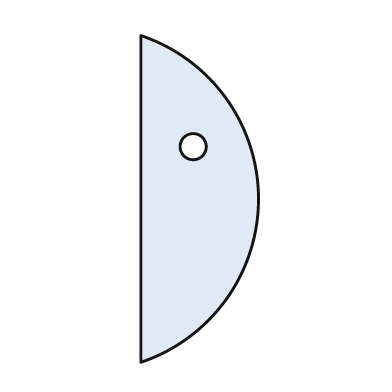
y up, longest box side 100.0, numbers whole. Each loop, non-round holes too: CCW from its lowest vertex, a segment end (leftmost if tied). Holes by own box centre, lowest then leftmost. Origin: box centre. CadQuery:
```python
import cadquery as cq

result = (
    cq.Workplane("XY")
    .moveTo(-18.0, -50.0)
    .threePointArc((18.0, 0.0), (-18.0, 50.0))
    .close()
    .moveTo(-2.0, 16.0)
    .circle(4.0)
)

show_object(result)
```